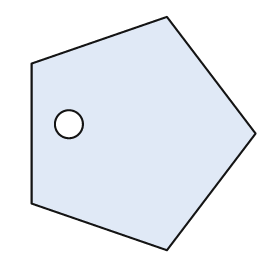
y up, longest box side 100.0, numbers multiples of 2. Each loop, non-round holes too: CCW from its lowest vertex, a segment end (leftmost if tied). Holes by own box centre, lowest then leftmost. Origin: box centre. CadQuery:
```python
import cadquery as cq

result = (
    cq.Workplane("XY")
    .moveTo(10.0, -50.0)
    .lineTo(48.0, 0.0)
    .lineTo(10.0, 50.0)
    .lineTo(-48.0, 30.0)
    .lineTo(-48.0, -30.0)
    .close()
    .moveTo(-32.0, 4.0)
    .circle(6.0)
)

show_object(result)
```